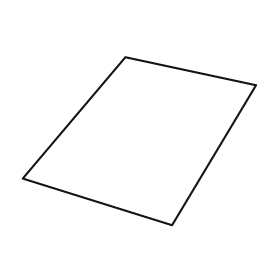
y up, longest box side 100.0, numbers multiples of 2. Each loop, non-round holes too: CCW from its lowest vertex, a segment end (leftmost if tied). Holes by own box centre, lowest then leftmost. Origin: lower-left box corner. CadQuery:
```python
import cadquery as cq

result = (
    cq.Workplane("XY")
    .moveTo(64.0, 0.0)
    .lineTo(100.0, 60.0)
    .lineTo(44.0, 72.0)
    .lineTo(0.0, 20.0)
    .close()
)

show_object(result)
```